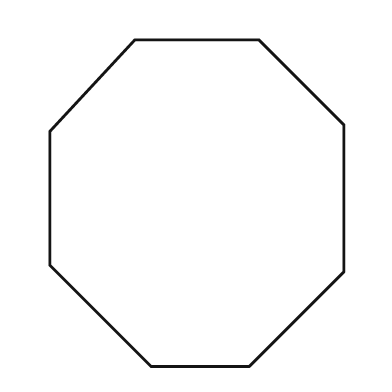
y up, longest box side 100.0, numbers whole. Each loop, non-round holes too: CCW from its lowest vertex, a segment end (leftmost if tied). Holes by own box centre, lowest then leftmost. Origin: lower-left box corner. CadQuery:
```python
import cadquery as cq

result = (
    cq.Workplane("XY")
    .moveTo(31.0, 0.0)
    .lineTo(61.0, 0.0)
    .lineTo(90.0, 29.0)
    .lineTo(90.0, 74.0)
    .lineTo(64.0, 100.0)
    .lineTo(26.0, 100.0)
    .lineTo(0.0, 72.0)
    .lineTo(0.0, 31.0)
    .close()
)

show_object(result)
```